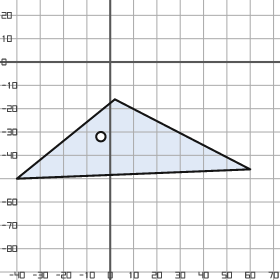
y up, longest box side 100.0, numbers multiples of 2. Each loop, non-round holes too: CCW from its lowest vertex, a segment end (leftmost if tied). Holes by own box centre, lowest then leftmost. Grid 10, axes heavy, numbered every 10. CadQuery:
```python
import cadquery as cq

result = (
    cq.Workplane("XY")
    .moveTo(-40.0, -50.0)
    .lineTo(60.0, -46.0)
    .lineTo(2.0, -16.0)
    .close()
    .moveTo(-4.0, -32.0)
    .circle(2.0)
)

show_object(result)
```